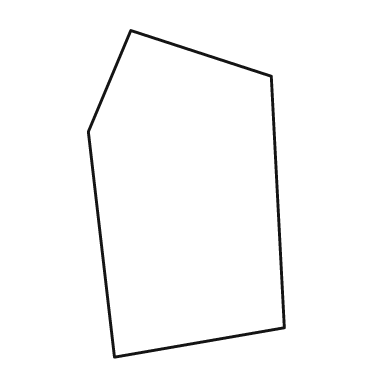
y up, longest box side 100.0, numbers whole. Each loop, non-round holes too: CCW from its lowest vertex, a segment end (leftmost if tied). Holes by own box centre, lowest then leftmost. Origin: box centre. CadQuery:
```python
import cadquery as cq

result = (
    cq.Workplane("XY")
    .moveTo(-22.0, -50.0)
    .lineTo(30.0, -41.0)
    .lineTo(26.0, 36.0)
    .lineTo(-17.0, 50.0)
    .lineTo(-30.0, 19.0)
    .close()
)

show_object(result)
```